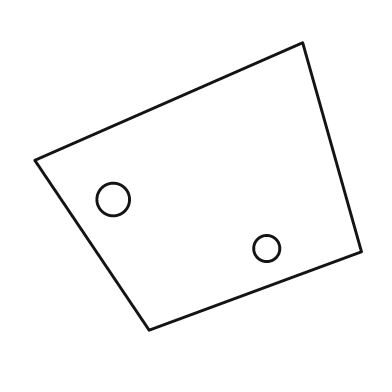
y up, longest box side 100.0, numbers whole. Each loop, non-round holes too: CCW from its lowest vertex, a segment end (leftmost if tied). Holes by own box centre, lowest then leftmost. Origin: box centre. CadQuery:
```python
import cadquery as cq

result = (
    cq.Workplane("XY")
    .moveTo(-15.0, -44.0)
    .lineTo(50.0, -20.0)
    .lineTo(32.0, 44.0)
    .lineTo(-50.0, 8.0)
    .close()
    .moveTo(21.0, -19.0)
    .circle(4.0)
    .moveTo(-26.0, -4.0)
    .circle(5.0)
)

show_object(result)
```